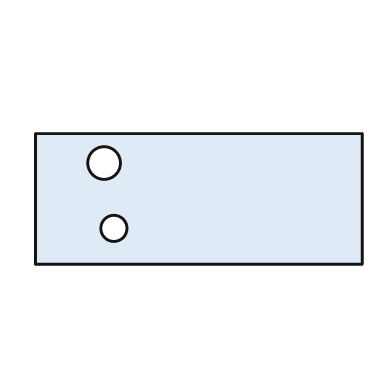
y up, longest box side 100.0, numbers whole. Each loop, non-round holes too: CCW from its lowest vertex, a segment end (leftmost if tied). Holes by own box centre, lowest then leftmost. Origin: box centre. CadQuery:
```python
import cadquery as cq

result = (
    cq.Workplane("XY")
    .moveTo(-50.0, -20.0)
    .lineTo(50.0, -20.0)
    .lineTo(50.0, 20.0)
    .lineTo(-50.0, 20.0)
    .close()
    .moveTo(-26.0, -9.0)
    .circle(4.0)
    .moveTo(-29.0, 11.0)
    .circle(5.0)
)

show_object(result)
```